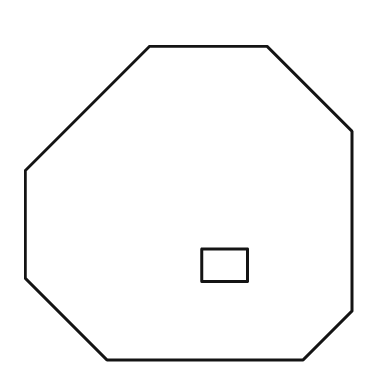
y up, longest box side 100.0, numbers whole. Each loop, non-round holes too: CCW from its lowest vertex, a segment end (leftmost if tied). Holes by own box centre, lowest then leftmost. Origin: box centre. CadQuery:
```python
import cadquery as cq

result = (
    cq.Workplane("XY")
    .moveTo(-25.0, -48.0)
    .lineTo(35.0, -48.0)
    .lineTo(50.0, -33.0)
    .lineTo(50.0, 22.0)
    .lineTo(24.0, 48.0)
    .lineTo(-12.0, 48.0)
    .lineTo(-50.0, 10.0)
    .lineTo(-50.0, -23.0)
    .close()
    .moveTo(4.0, -24.0)
    .lineTo(18.0, -24.0)
    .lineTo(18.0, -14.0)
    .lineTo(4.0, -14.0)
    .close()
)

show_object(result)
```